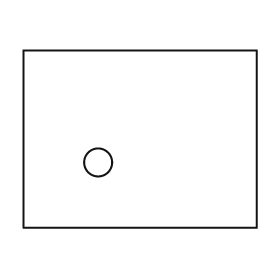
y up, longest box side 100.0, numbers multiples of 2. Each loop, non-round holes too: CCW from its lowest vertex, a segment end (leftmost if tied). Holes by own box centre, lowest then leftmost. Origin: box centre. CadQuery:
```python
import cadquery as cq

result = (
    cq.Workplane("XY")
    .moveTo(-50.0, -38.0)
    .lineTo(50.0, -38.0)
    .lineTo(50.0, 38.0)
    .lineTo(-50.0, 38.0)
    .close()
    .moveTo(-18.0, -10.0)
    .circle(6.0)
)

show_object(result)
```